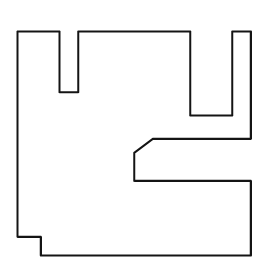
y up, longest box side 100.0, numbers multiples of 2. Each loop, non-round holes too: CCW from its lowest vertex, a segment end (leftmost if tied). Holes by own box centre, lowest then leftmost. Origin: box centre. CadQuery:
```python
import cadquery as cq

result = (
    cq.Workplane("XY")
    .moveTo(-40.0, -48.0)
    .lineTo(50.0, -48.0)
    .lineTo(50.0, -16.0)
    .lineTo(0.0, -16.0)
    .lineTo(0.0, -4.0)
    .lineTo(8.0, 2.0)
    .lineTo(50.0, 2.0)
    .lineTo(50.0, 48.0)
    .lineTo(42.0, 48.0)
    .lineTo(42.0, 12.0)
    .lineTo(24.0, 12.0)
    .lineTo(24.0, 48.0)
    .lineTo(-24.0, 48.0)
    .lineTo(-24.0, 22.0)
    .lineTo(-32.0, 22.0)
    .lineTo(-32.0, 48.0)
    .lineTo(-50.0, 48.0)
    .lineTo(-50.0, -40.0)
    .lineTo(-40.0, -40.0)
    .close()
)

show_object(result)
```